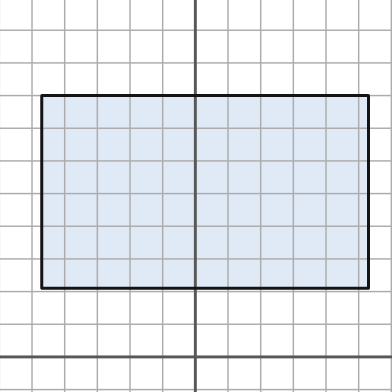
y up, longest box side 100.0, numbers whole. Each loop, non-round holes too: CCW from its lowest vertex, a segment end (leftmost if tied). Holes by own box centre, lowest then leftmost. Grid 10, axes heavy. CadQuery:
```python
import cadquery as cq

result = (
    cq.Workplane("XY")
    .moveTo(-47.0, 21.0)
    .lineTo(53.0, 21.0)
    .lineTo(53.0, 80.0)
    .lineTo(-47.0, 80.0)
    .close()
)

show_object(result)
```